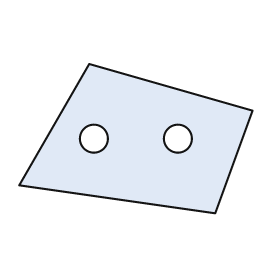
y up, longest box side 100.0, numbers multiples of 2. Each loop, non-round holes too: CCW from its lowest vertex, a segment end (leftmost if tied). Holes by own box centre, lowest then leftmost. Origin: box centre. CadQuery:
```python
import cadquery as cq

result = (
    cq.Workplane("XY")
    .moveTo(34.0, -32.0)
    .lineTo(50.0, 12.0)
    .lineTo(-20.0, 32.0)
    .lineTo(-50.0, -20.0)
    .close()
    .moveTo(-18.0, 0.0)
    .circle(6.0)
    .moveTo(18.0, 0.0)
    .circle(6.0)
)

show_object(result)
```